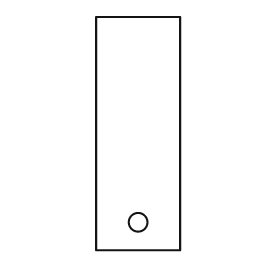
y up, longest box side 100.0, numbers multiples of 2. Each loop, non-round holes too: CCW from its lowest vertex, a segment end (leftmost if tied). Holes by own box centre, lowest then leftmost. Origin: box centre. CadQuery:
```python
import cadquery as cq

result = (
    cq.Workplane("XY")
    .moveTo(-18.0, -50.0)
    .lineTo(18.0, -50.0)
    .lineTo(18.0, 50.0)
    .lineTo(-18.0, 50.0)
    .close()
    .moveTo(0.0, -38.0)
    .circle(4.0)
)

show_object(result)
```